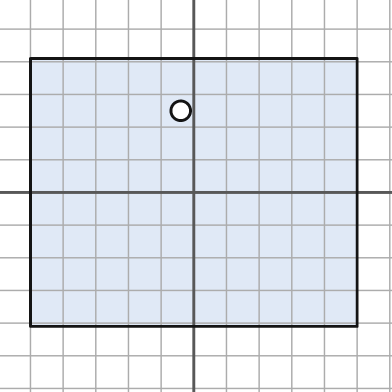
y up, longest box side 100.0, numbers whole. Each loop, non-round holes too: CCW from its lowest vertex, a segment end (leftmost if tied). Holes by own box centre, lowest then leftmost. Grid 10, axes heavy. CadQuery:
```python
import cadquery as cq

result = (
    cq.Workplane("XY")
    .moveTo(-50.0, -41.0)
    .lineTo(50.0, -41.0)
    .lineTo(50.0, 41.0)
    .lineTo(-50.0, 41.0)
    .close()
    .moveTo(-4.0, 25.0)
    .circle(3.0)
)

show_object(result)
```